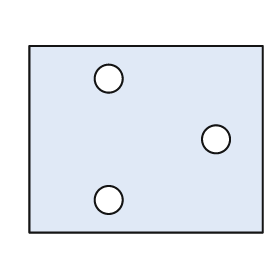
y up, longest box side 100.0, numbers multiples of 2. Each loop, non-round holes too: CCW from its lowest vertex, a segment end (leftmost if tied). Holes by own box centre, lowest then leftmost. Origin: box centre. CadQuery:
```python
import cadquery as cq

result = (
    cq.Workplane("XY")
    .moveTo(-50.0, -40.0)
    .lineTo(50.0, -40.0)
    .lineTo(50.0, 40.0)
    .lineTo(-50.0, 40.0)
    .close()
    .moveTo(-16.0, -26.0)
    .circle(6.0)
    .moveTo(30.0, 0.0)
    .circle(6.0)
    .moveTo(-16.0, 26.0)
    .circle(6.0)
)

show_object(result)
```